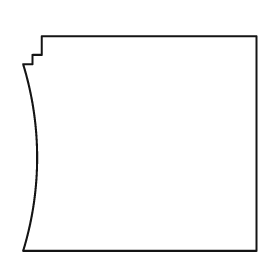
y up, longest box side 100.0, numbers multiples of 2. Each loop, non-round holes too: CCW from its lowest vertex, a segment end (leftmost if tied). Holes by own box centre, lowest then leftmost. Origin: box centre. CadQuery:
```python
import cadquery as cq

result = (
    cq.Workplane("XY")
    .moveTo(-50.0, -46.0)
    .lineTo(50.0, -46.0)
    .lineTo(50.0, 46.0)
    .lineTo(-42.0, 46.0)
    .lineTo(-42.0, 38.0)
    .lineTo(-46.0, 38.0)
    .lineTo(-46.0, 34.0)
    .lineTo(-50.0, 34.0)
    .threePointArc((-44.0, -6.0), (-50.0, -46.0))
    .close()
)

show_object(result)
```